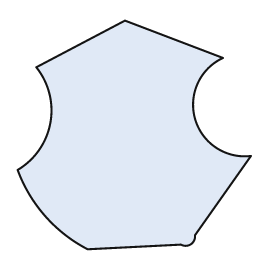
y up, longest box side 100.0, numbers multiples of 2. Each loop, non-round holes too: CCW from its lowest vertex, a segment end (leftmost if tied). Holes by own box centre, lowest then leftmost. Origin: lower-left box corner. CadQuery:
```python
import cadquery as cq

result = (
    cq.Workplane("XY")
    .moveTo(30.0, 0.0)
    .lineTo(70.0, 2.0)
    .threePointArc((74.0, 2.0), (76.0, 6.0))
    .lineTo(100.0, 40.0)
    .threePointArc((76.0, 56.0), (88.0, 82.0))
    .lineTo(46.0, 98.0)
    .lineTo(8.0, 78.0)
    .threePointArc((14.0, 54.0), (0.0, 34.0))
    .threePointArc((12.0, 14.0), (30.0, 0.0))
    .close()
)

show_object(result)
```